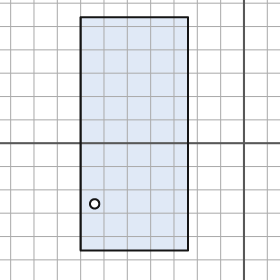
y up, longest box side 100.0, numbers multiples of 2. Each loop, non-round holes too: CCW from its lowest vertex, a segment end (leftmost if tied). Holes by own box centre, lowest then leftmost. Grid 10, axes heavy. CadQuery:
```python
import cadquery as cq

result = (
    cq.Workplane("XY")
    .moveTo(-70.0, -46.0)
    .lineTo(-24.0, -46.0)
    .lineTo(-24.0, 54.0)
    .lineTo(-70.0, 54.0)
    .close()
    .moveTo(-64.0, -26.0)
    .circle(2.0)
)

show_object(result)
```